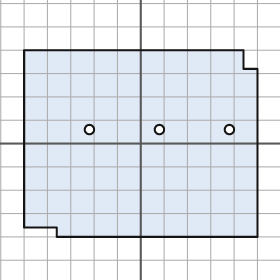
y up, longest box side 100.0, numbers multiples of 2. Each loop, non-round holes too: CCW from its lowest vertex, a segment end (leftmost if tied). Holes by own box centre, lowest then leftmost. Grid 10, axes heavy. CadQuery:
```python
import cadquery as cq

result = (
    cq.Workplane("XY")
    .moveTo(-36.0, -40.0)
    .lineTo(50.0, -40.0)
    .lineTo(50.0, 32.0)
    .lineTo(44.0, 32.0)
    .lineTo(44.0, 40.0)
    .lineTo(-50.0, 40.0)
    .lineTo(-50.0, -36.0)
    .lineTo(-36.0, -36.0)
    .close()
    .moveTo(-22.0, 6.0)
    .circle(2.0)
    .moveTo(8.0, 6.0)
    .circle(2.0)
    .moveTo(38.0, 6.0)
    .circle(2.0)
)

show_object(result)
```